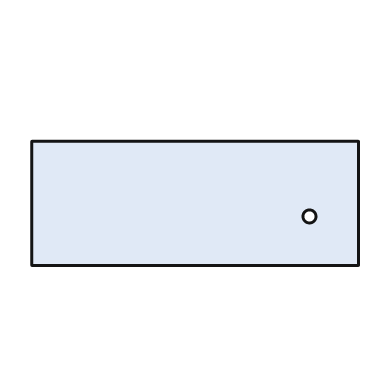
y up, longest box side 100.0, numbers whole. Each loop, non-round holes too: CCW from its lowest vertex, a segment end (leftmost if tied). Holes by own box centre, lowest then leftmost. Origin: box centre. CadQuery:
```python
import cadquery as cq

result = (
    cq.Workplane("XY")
    .moveTo(-50.0, -19.0)
    .lineTo(50.0, -19.0)
    .lineTo(50.0, 19.0)
    .lineTo(-50.0, 19.0)
    .close()
    .moveTo(35.0, -4.0)
    .circle(2.0)
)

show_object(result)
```